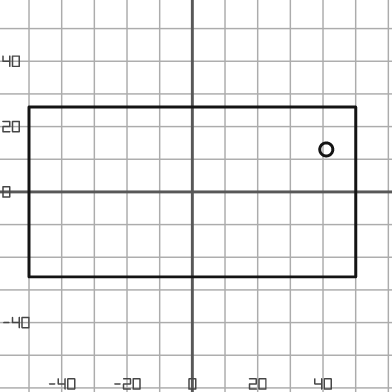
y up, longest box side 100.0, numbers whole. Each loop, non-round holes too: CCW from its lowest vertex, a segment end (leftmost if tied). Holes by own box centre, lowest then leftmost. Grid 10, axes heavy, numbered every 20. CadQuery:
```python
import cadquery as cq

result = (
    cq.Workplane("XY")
    .moveTo(-50.0, -26.0)
    .lineTo(50.0, -26.0)
    .lineTo(50.0, 26.0)
    .lineTo(-50.0, 26.0)
    .close()
    .moveTo(41.0, 13.0)
    .circle(2.0)
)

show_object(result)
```